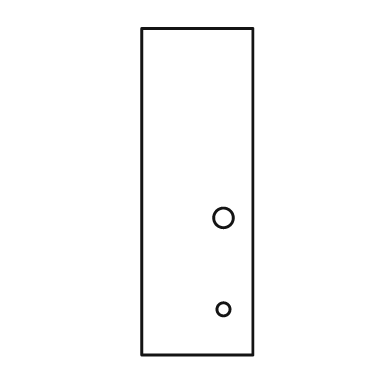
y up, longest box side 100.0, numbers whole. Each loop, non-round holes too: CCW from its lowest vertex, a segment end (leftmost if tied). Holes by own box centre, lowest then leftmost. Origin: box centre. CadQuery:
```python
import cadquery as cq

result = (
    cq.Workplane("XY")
    .moveTo(-17.0, -50.0)
    .lineTo(17.0, -50.0)
    .lineTo(17.0, 50.0)
    .lineTo(-17.0, 50.0)
    .close()
    .moveTo(8.0, -36.0)
    .circle(2.0)
    .moveTo(8.0, -8.0)
    .circle(3.0)
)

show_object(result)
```